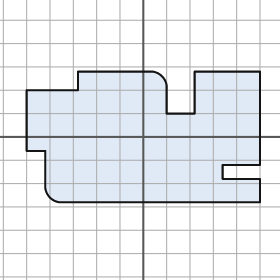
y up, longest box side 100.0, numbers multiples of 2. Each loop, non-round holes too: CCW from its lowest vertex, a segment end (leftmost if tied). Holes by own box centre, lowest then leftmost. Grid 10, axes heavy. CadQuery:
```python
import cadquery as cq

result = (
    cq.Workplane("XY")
    .moveTo(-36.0, -28.0)
    .lineTo(50.0, -28.0)
    .lineTo(50.0, -18.0)
    .lineTo(34.0, -18.0)
    .lineTo(34.0, -12.0)
    .lineTo(50.0, -12.0)
    .lineTo(50.0, 28.0)
    .lineTo(22.0, 28.0)
    .lineTo(22.0, 10.0)
    .lineTo(10.0, 10.0)
    .lineTo(10.0, 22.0)
    .threePointArc((8.0, 26.0), (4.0, 28.0))
    .lineTo(-28.0, 28.0)
    .lineTo(-28.0, 20.0)
    .lineTo(-50.0, 20.0)
    .lineTo(-50.0, -6.0)
    .lineTo(-42.0, -6.0)
    .lineTo(-42.0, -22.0)
    .threePointArc((-40.0, -26.0), (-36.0, -28.0))
    .close()
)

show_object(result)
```